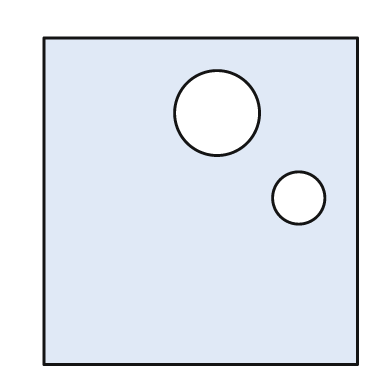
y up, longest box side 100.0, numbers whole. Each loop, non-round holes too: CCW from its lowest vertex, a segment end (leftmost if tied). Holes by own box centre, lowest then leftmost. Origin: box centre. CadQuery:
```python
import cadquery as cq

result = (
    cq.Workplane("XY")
    .moveTo(-48.0, -50.0)
    .lineTo(48.0, -50.0)
    .lineTo(48.0, 50.0)
    .lineTo(-48.0, 50.0)
    .close()
    .moveTo(30.0, 1.0)
    .circle(8.0)
    .moveTo(5.0, 27.0)
    .circle(13.0)
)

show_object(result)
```